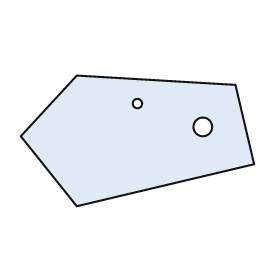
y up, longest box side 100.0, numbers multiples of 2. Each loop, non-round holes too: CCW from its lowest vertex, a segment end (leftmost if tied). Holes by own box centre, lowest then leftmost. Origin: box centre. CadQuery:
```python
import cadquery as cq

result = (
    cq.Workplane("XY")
    .moveTo(-26.0, -28.0)
    .lineTo(50.0, -10.0)
    .lineTo(42.0, 24.0)
    .lineTo(-26.0, 28.0)
    .lineTo(-50.0, 2.0)
    .close()
    .moveTo(28.0, 6.0)
    .circle(4.0)
    .moveTo(0.0, 16.0)
    .circle(2.0)
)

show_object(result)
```